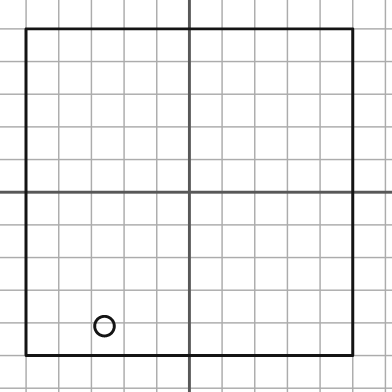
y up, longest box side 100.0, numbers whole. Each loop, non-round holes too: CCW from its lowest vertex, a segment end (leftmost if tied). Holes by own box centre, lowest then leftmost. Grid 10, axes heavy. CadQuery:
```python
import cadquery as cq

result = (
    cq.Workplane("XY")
    .moveTo(-50.0, -50.0)
    .lineTo(50.0, -50.0)
    .lineTo(50.0, 50.0)
    .lineTo(-50.0, 50.0)
    .close()
    .moveTo(-26.0, -41.0)
    .circle(3.0)
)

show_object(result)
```